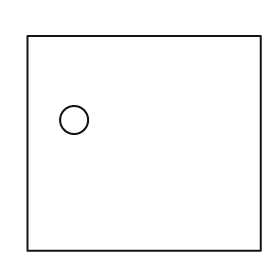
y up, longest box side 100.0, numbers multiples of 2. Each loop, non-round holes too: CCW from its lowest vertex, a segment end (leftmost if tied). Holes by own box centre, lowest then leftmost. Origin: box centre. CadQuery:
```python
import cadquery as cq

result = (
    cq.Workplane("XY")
    .moveTo(-50.0, -46.0)
    .lineTo(50.0, -46.0)
    .lineTo(50.0, 46.0)
    .lineTo(-50.0, 46.0)
    .close()
    .moveTo(-30.0, 10.0)
    .circle(6.0)
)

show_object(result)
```